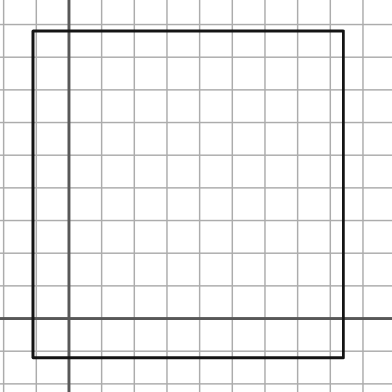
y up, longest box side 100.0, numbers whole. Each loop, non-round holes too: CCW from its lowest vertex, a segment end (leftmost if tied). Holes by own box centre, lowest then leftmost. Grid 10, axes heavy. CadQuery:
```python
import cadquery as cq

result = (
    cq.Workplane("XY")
    .moveTo(-11.0, -12.0)
    .lineTo(84.0, -12.0)
    .lineTo(84.0, 88.0)
    .lineTo(-11.0, 88.0)
    .close()
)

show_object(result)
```